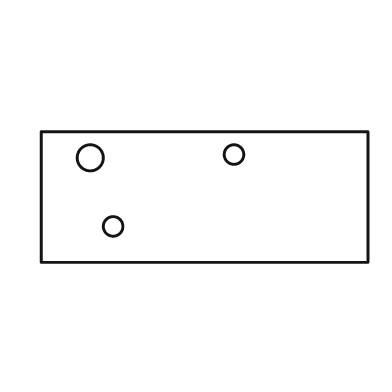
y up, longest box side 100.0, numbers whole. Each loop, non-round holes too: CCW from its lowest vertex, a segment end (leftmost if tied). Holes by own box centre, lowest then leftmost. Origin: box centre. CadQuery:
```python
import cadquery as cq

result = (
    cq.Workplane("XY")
    .moveTo(-50.0, -20.0)
    .lineTo(50.0, -20.0)
    .lineTo(50.0, 20.0)
    .lineTo(-50.0, 20.0)
    .close()
    .moveTo(-28.0, -9.0)
    .circle(3.0)
    .moveTo(-35.0, 12.0)
    .circle(4.0)
    .moveTo(9.0, 13.0)
    .circle(3.0)
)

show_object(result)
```